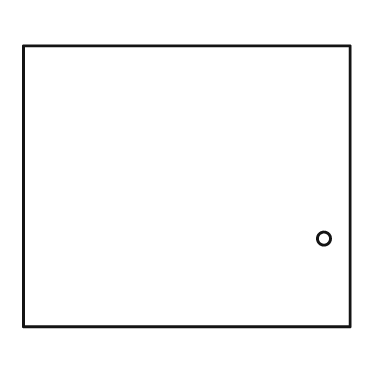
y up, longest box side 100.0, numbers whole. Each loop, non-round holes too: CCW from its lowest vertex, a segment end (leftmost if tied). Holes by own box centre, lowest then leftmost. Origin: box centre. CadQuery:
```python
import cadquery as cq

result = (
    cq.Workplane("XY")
    .moveTo(-50.0, -43.0)
    .lineTo(50.0, -43.0)
    .lineTo(50.0, 43.0)
    .lineTo(-50.0, 43.0)
    .close()
    .moveTo(42.0, -16.0)
    .circle(2.0)
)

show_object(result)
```